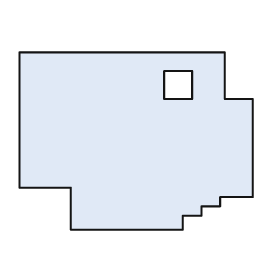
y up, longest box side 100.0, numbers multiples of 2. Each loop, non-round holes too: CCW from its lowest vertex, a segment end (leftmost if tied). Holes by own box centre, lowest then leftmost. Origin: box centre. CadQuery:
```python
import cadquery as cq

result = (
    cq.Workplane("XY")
    .moveTo(-28.0, -38.0)
    .lineTo(20.0, -38.0)
    .lineTo(20.0, -32.0)
    .lineTo(28.0, -32.0)
    .lineTo(28.0, -28.0)
    .lineTo(36.0, -28.0)
    .lineTo(36.0, -24.0)
    .lineTo(50.0, -24.0)
    .lineTo(50.0, 18.0)
    .lineTo(38.0, 18.0)
    .lineTo(38.0, 38.0)
    .lineTo(-50.0, 38.0)
    .lineTo(-50.0, -20.0)
    .lineTo(-28.0, -20.0)
    .close()
    .moveTo(12.0, 18.0)
    .lineTo(24.0, 18.0)
    .lineTo(24.0, 30.0)
    .lineTo(12.0, 30.0)
    .close()
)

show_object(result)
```